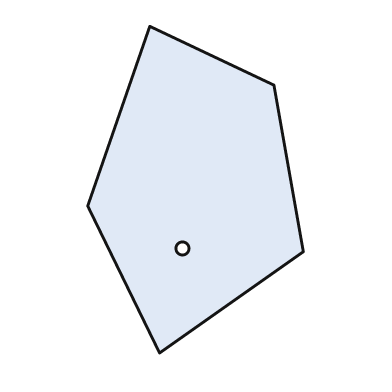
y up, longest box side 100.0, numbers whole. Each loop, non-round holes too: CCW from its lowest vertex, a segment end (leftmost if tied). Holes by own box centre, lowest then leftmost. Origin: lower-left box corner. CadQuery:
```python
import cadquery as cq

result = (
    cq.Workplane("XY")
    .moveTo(22.0, 0.0)
    .lineTo(66.0, 31.0)
    .lineTo(57.0, 82.0)
    .lineTo(19.0, 100.0)
    .lineTo(0.0, 45.0)
    .close()
    .moveTo(29.0, 32.0)
    .circle(2.0)
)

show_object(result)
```